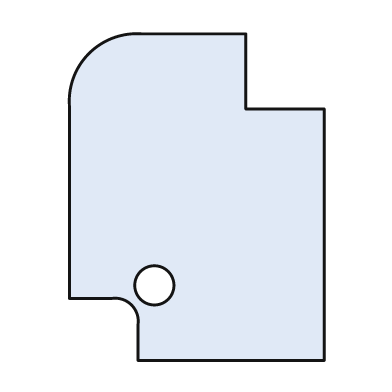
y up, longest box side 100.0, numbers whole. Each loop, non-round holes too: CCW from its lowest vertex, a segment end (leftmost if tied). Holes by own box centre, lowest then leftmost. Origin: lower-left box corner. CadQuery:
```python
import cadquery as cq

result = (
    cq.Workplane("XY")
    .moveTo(21.0, 0.0)
    .lineTo(78.0, 0.0)
    .lineTo(78.0, 77.0)
    .lineTo(54.0, 77.0)
    .lineTo(54.0, 100.0)
    .lineTo(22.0, 100.0)
    .threePointArc((6.0, 94.0), (0.0, 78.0))
    .lineTo(0.0, 19.0)
    .lineTo(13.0, 19.0)
    .threePointArc((19.0, 17.0), (21.0, 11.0))
    .close()
    .moveTo(26.0, 23.0)
    .circle(6.0)
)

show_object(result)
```